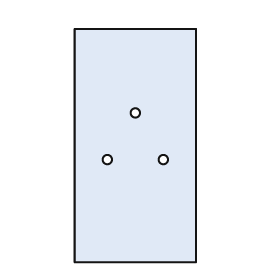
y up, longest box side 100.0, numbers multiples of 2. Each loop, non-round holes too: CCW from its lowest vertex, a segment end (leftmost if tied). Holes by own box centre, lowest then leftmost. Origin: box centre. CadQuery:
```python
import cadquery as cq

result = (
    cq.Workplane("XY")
    .moveTo(-26.0, -50.0)
    .lineTo(26.0, -50.0)
    .lineTo(26.0, 50.0)
    .lineTo(-26.0, 50.0)
    .close()
    .moveTo(-12.0, -6.0)
    .circle(2.0)
    .moveTo(12.0, -6.0)
    .circle(2.0)
    .moveTo(0.0, 14.0)
    .circle(2.0)
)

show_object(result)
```